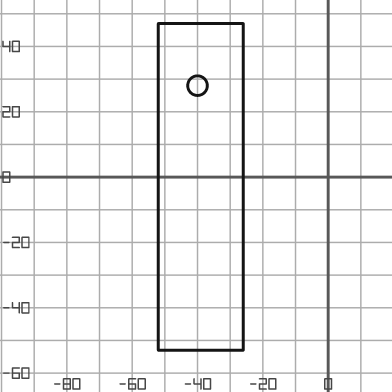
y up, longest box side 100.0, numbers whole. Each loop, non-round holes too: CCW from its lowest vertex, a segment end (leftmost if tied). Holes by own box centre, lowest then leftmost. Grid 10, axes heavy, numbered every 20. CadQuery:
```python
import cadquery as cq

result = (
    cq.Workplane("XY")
    .moveTo(-52.0, -53.0)
    .lineTo(-26.0, -53.0)
    .lineTo(-26.0, 47.0)
    .lineTo(-52.0, 47.0)
    .close()
    .moveTo(-40.0, 28.0)
    .circle(3.0)
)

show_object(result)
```